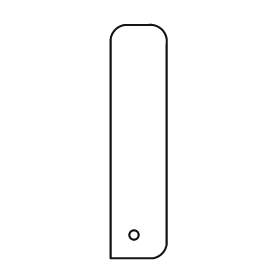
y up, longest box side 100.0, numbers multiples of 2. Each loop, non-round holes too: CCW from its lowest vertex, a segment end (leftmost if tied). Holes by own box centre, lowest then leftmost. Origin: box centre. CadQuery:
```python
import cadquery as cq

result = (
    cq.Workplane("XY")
    .moveTo(-12.0, -50.0)
    .lineTo(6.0, -50.0)
    .threePointArc((10.0, -48.0), (12.0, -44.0))
    .lineTo(12.0, 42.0)
    .threePointArc((10.0, 48.0), (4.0, 50.0))
    .lineTo(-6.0, 50.0)
    .threePointArc((-10.0, 48.0), (-12.0, 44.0))
    .close()
    .moveTo(-2.0, -40.0)
    .circle(2.0)
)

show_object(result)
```